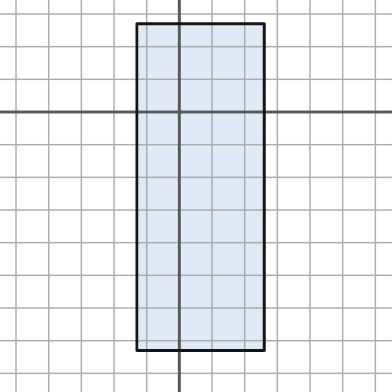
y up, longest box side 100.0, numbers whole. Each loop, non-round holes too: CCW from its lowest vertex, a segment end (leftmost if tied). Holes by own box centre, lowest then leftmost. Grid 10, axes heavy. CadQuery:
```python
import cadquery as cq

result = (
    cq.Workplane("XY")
    .moveTo(-13.0, -73.0)
    .lineTo(26.0, -73.0)
    .lineTo(26.0, 27.0)
    .lineTo(-13.0, 27.0)
    .close()
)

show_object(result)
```